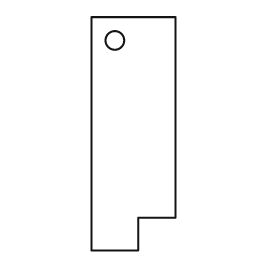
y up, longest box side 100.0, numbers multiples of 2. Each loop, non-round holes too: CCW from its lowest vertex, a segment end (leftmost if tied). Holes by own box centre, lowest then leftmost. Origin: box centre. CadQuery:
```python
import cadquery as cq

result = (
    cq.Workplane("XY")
    .moveTo(-18.0, -50.0)
    .lineTo(2.0, -50.0)
    .lineTo(2.0, -36.0)
    .lineTo(18.0, -36.0)
    .lineTo(18.0, 50.0)
    .lineTo(-18.0, 50.0)
    .close()
    .moveTo(-8.0, 40.0)
    .circle(4.0)
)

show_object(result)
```